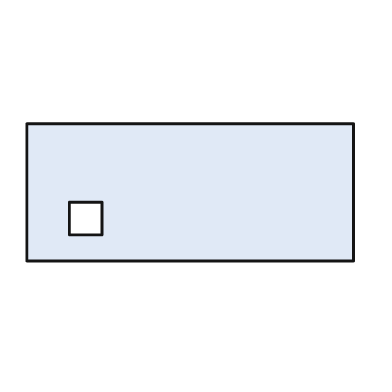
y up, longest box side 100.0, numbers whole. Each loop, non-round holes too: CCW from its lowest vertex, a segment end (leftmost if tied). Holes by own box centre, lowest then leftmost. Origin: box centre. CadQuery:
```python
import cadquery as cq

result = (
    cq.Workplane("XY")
    .moveTo(-50.0, -21.0)
    .lineTo(50.0, -21.0)
    .lineTo(50.0, 21.0)
    .lineTo(-50.0, 21.0)
    .close()
    .moveTo(-37.0, -13.0)
    .lineTo(-27.0, -13.0)
    .lineTo(-27.0, -3.0)
    .lineTo(-37.0, -3.0)
    .close()
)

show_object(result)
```